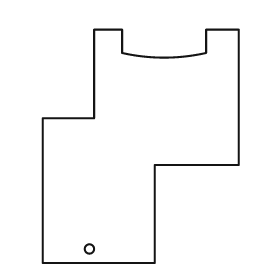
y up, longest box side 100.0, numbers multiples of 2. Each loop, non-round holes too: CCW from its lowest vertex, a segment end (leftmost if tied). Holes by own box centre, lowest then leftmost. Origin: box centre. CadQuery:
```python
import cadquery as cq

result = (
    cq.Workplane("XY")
    .moveTo(-42.0, -50.0)
    .lineTo(6.0, -50.0)
    .lineTo(6.0, -8.0)
    .lineTo(42.0, -8.0)
    .lineTo(42.0, 50.0)
    .lineTo(28.0, 50.0)
    .lineTo(28.0, 40.0)
    .threePointArc((10.0, 38.0), (-8.0, 40.0))
    .lineTo(-8.0, 50.0)
    .lineTo(-20.0, 50.0)
    .lineTo(-20.0, 12.0)
    .lineTo(-42.0, 12.0)
    .close()
    .moveTo(-22.0, -44.0)
    .circle(2.0)
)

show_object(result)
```